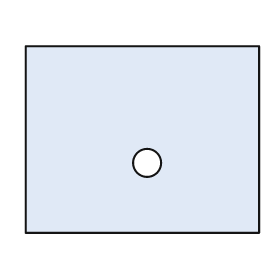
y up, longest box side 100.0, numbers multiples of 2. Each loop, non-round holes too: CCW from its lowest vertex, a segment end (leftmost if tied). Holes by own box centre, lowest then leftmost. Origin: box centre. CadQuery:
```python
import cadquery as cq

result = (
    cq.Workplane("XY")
    .moveTo(-50.0, -40.0)
    .lineTo(50.0, -40.0)
    .lineTo(50.0, 40.0)
    .lineTo(-50.0, 40.0)
    .close()
    .moveTo(2.0, -10.0)
    .circle(6.0)
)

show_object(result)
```